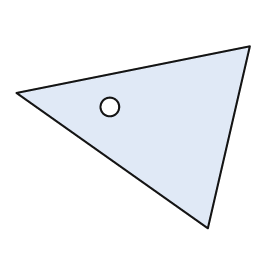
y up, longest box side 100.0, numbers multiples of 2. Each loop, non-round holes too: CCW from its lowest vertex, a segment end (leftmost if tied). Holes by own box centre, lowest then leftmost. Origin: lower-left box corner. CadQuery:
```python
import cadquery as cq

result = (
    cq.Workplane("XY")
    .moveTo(82.0, 0.0)
    .lineTo(100.0, 78.0)
    .lineTo(0.0, 58.0)
    .close()
    .moveTo(40.0, 52.0)
    .circle(4.0)
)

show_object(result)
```